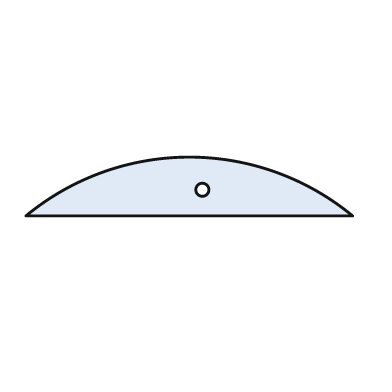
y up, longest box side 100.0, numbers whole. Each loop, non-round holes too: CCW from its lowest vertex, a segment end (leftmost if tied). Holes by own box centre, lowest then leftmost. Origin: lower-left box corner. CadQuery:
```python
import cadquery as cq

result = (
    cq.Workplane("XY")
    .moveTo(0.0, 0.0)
    .lineTo(100.0, 0.0)
    .threePointArc((50.0, 18.0), (0.0, 0.0))
    .close()
    .moveTo(54.0, 8.0)
    .circle(2.0)
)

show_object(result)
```